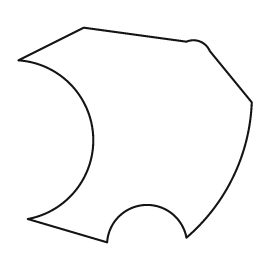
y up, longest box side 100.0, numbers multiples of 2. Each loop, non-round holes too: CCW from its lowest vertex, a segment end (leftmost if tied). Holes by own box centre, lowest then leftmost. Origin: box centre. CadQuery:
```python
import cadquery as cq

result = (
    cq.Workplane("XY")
    .moveTo(-12.0, -46.0)
    .threePointArc((4.0, -30.0), (22.0, -44.0))
    .threePointArc((42.0, -18.0), (50.0, 14.0))
    .lineTo(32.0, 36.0)
    .threePointArc((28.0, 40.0), (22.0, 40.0))
    .lineTo(-22.0, 46.0)
    .lineTo(-50.0, 32.0)
    .threePointArc((-18.0, 0.0), (-46.0, -36.0))
    .close()
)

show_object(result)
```